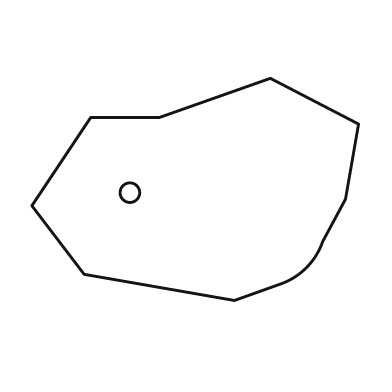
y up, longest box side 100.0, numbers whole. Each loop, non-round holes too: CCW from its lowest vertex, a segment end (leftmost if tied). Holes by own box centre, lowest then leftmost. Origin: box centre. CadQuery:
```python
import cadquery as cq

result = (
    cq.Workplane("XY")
    .moveTo(12.0, -34.0)
    .lineTo(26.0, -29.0)
    .threePointArc((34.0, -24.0), (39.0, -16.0))
    .lineTo(46.0, -3.0)
    .lineTo(50.0, 20.0)
    .lineTo(23.0, 34.0)
    .lineTo(-11.0, 22.0)
    .lineTo(-32.0, 22.0)
    .lineTo(-50.0, -5.0)
    .lineTo(-34.0, -26.0)
    .close()
    .moveTo(-20.0, -1.0)
    .circle(3.0)
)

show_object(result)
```